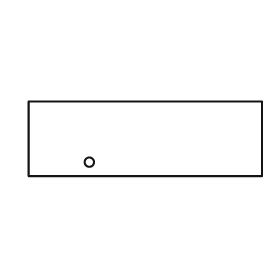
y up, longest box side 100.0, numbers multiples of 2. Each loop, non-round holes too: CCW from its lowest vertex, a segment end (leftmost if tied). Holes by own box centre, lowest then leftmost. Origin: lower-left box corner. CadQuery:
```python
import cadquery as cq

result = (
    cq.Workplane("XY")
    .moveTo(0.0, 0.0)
    .lineTo(100.0, 0.0)
    .lineTo(100.0, 32.0)
    .lineTo(0.0, 32.0)
    .close()
    .moveTo(26.0, 6.0)
    .circle(2.0)
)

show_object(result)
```